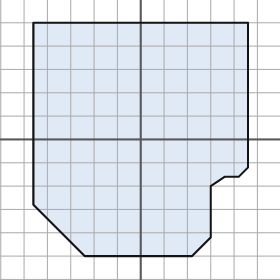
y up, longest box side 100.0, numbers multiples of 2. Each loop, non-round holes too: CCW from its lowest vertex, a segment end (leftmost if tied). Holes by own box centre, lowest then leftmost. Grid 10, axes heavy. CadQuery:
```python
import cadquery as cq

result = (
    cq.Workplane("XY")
    .moveTo(-24.0, -50.0)
    .lineTo(22.0, -50.0)
    .lineTo(30.0, -42.0)
    .lineTo(30.0, -20.0)
    .lineTo(36.0, -16.0)
    .lineTo(42.0, -16.0)
    .lineTo(46.0, -12.0)
    .lineTo(46.0, 50.0)
    .lineTo(-46.0, 50.0)
    .lineTo(-46.0, -28.0)
    .close()
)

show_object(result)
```